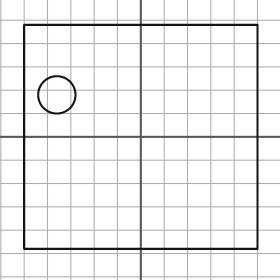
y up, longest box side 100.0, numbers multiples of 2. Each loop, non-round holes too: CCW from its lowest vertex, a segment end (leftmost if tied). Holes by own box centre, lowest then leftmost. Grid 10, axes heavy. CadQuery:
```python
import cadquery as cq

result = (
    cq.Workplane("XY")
    .moveTo(-50.0, -48.0)
    .lineTo(50.0, -48.0)
    .lineTo(50.0, 48.0)
    .lineTo(-50.0, 48.0)
    .close()
    .moveTo(-36.0, 18.0)
    .circle(8.0)
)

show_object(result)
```